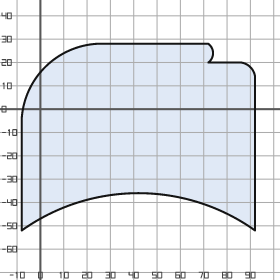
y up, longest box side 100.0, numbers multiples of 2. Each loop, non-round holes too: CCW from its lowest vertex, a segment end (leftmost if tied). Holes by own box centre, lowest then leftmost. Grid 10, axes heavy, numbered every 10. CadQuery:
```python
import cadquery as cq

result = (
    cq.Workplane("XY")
    .moveTo(-8.0, -52.0)
    .threePointArc((42.0, -36.0), (92.0, -52.0))
    .lineTo(92.0, 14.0)
    .threePointArc((90.0, 18.0), (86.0, 20.0))
    .lineTo(72.0, 20.0)
    .threePointArc((74.0, 24.0), (72.0, 28.0))
    .lineTo(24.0, 28.0)
    .threePointArc((2.0, 18.0), (-8.0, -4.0))
    .close()
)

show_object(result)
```